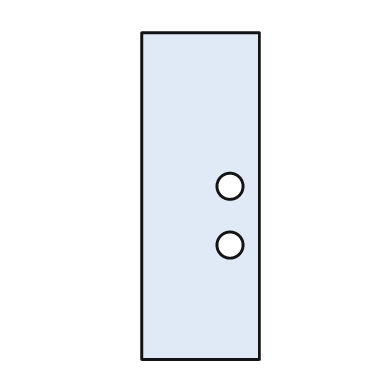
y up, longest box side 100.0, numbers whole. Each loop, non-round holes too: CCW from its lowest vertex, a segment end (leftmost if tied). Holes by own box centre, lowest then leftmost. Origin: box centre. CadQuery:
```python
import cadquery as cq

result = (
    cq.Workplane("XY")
    .moveTo(-18.0, -50.0)
    .lineTo(18.0, -50.0)
    .lineTo(18.0, 50.0)
    .lineTo(-18.0, 50.0)
    .close()
    .moveTo(9.0, -15.0)
    .circle(4.0)
    .moveTo(9.0, 3.0)
    .circle(4.0)
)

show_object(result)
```